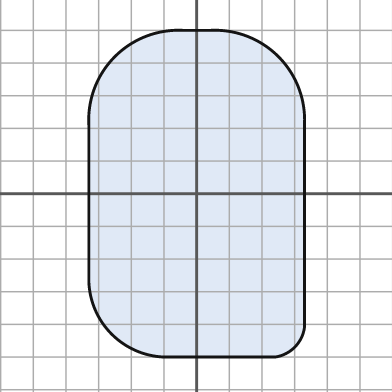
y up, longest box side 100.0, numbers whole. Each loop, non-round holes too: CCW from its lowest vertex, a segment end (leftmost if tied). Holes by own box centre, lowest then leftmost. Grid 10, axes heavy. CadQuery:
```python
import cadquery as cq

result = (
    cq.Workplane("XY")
    .moveTo(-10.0, -50.0)
    .lineTo(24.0, -50.0)
    .threePointArc((30.0, -47.0), (33.0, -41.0))
    .lineTo(33.0, 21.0)
    .threePointArc((25.0, 42.0), (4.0, 50.0))
    .lineTo(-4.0, 50.0)
    .threePointArc((-25.0, 42.0), (-33.0, 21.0))
    .lineTo(-33.0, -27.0)
    .threePointArc((-26.0, -43.0), (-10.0, -50.0))
    .close()
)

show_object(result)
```